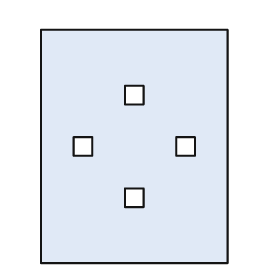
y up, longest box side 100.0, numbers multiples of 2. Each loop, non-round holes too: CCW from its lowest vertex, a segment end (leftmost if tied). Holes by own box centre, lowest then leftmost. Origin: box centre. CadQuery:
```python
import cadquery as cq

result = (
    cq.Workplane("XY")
    .moveTo(-40.0, -50.0)
    .lineTo(40.0, -50.0)
    .lineTo(40.0, 50.0)
    .lineTo(-40.0, 50.0)
    .close()
    .moveTo(-4.0, -26.0)
    .lineTo(4.0, -26.0)
    .lineTo(4.0, -18.0)
    .lineTo(-4.0, -18.0)
    .close()
    .moveTo(-26.0, -4.0)
    .lineTo(-18.0, -4.0)
    .lineTo(-18.0, 4.0)
    .lineTo(-26.0, 4.0)
    .close()
    .moveTo(18.0, -4.0)
    .lineTo(26.0, -4.0)
    .lineTo(26.0, 4.0)
    .lineTo(18.0, 4.0)
    .close()
    .moveTo(-4.0, 18.0)
    .lineTo(4.0, 18.0)
    .lineTo(4.0, 26.0)
    .lineTo(-4.0, 26.0)
    .close()
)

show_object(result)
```